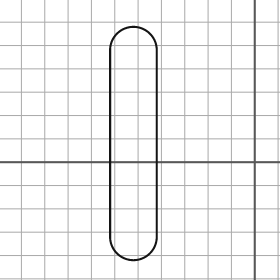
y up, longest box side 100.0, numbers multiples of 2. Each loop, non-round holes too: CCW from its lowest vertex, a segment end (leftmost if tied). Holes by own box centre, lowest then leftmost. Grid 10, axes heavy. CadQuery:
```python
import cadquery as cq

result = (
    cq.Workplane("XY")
    .moveTo(-62.0, -32.0)
    .threePointArc((-52.0, -42.0), (-42.0, -32.0))
    .lineTo(-42.0, 48.0)
    .threePointArc((-52.0, 58.0), (-62.0, 48.0))
    .close()
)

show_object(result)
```